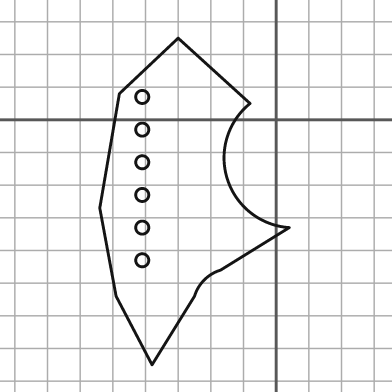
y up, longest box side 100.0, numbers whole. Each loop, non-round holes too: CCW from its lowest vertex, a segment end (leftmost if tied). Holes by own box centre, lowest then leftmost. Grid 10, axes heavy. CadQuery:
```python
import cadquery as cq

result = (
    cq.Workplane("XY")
    .moveTo(-38.0, -75.0)
    .lineTo(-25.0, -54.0)
    .threePointArc((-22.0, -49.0), (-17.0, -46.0))
    .lineTo(4.0, -33.0)
    .threePointArc((-15.0, -18.0), (-8.0, 5.0))
    .lineTo(-30.0, 25.0)
    .lineTo(-48.0, 8.0)
    .lineTo(-54.0, -27.0)
    .lineTo(-49.0, -54.0)
    .close()
    .moveTo(-41.0, -43.0)
    .circle(2.0)
    .moveTo(-41.0, -33.0)
    .circle(2.0)
    .moveTo(-41.0, -23.0)
    .circle(2.0)
    .moveTo(-41.0, -13.0)
    .circle(2.0)
    .moveTo(-41.0, -3.0)
    .circle(2.0)
    .moveTo(-41.0, 7.0)
    .circle(2.0)
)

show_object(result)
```